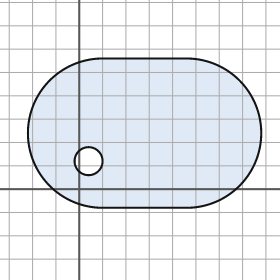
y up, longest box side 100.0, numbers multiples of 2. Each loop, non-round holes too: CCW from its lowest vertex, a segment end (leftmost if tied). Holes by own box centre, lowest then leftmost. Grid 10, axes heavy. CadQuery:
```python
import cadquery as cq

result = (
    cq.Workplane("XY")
    .moveTo(10.0, -8.0)
    .lineTo(46.0, -8.0)
    .threePointArc((78.0, 24.0), (46.0, 56.0))
    .lineTo(10.0, 56.0)
    .threePointArc((-22.0, 24.0), (10.0, -8.0))
    .close()
    .moveTo(4.0, 12.0)
    .circle(6.0)
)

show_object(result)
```